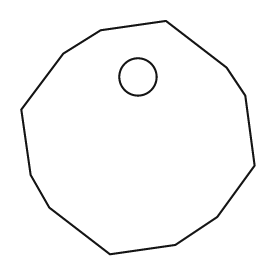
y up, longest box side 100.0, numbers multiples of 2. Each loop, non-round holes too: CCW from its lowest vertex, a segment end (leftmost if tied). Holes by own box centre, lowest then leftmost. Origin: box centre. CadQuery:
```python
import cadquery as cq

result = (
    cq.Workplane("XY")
    .moveTo(-12.0, -50.0)
    .lineTo(16.0, -46.0)
    .lineTo(34.0, -34.0)
    .lineTo(50.0, -12.0)
    .lineTo(46.0, 18.0)
    .lineTo(38.0, 30.0)
    .lineTo(12.0, 50.0)
    .lineTo(-16.0, 46.0)
    .lineTo(-32.0, 36.0)
    .lineTo(-50.0, 12.0)
    .lineTo(-46.0, -16.0)
    .lineTo(-38.0, -30.0)
    .close()
    .moveTo(0.0, 26.0)
    .circle(8.0)
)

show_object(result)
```